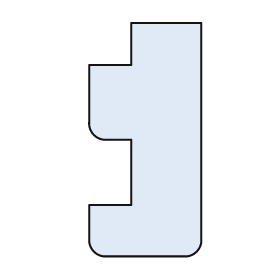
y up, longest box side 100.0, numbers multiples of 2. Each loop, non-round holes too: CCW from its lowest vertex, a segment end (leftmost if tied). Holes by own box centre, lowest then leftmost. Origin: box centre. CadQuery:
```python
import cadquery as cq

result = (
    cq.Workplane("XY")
    .moveTo(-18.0, -50.0)
    .lineTo(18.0, -50.0)
    .threePointArc((22.0, -48.0), (24.0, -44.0))
    .lineTo(24.0, 50.0)
    .lineTo(-6.0, 50.0)
    .lineTo(-6.0, 32.0)
    .lineTo(-24.0, 32.0)
    .lineTo(-24.0, 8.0)
    .threePointArc((-22.0, 2.0), (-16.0, 0.0))
    .lineTo(-6.0, 0.0)
    .lineTo(-6.0, -28.0)
    .lineTo(-24.0, -28.0)
    .lineTo(-24.0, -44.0)
    .threePointArc((-22.0, -48.0), (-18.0, -50.0))
    .close()
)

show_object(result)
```